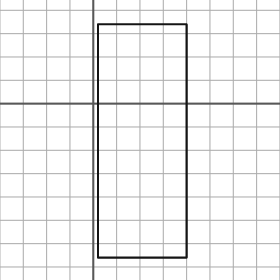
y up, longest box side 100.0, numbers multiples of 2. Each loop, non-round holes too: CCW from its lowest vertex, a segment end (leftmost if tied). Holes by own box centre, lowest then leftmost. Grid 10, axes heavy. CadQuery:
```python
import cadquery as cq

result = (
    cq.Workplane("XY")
    .moveTo(2.0, -66.0)
    .lineTo(40.0, -66.0)
    .lineTo(40.0, 34.0)
    .lineTo(2.0, 34.0)
    .close()
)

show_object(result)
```